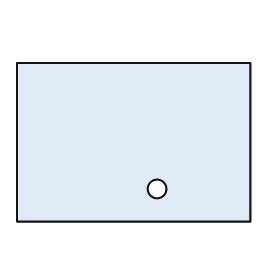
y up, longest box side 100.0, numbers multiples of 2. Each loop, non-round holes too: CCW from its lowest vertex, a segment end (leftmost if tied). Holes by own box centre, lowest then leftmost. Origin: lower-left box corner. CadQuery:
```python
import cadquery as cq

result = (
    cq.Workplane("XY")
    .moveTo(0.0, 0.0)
    .lineTo(100.0, 0.0)
    .lineTo(100.0, 68.0)
    .lineTo(0.0, 68.0)
    .close()
    .moveTo(60.0, 14.0)
    .circle(4.0)
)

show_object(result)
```